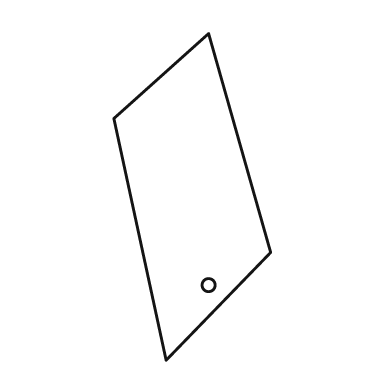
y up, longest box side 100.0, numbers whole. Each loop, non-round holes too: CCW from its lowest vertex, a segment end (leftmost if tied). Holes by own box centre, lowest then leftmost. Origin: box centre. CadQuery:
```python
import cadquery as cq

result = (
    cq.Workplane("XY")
    .moveTo(-8.0, -50.0)
    .lineTo(24.0, -17.0)
    .lineTo(5.0, 50.0)
    .lineTo(-24.0, 24.0)
    .close()
    .moveTo(5.0, -27.0)
    .circle(2.0)
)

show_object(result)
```